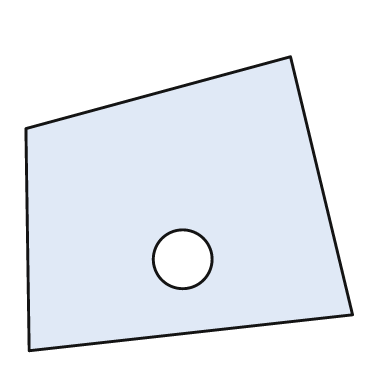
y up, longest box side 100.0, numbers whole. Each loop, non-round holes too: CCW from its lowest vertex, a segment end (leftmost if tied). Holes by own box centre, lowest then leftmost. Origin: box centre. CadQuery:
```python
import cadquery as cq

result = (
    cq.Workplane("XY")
    .moveTo(-49.0, -45.0)
    .lineTo(50.0, -34.0)
    .lineTo(31.0, 45.0)
    .lineTo(-50.0, 23.0)
    .close()
    .moveTo(-2.0, -17.0)
    .circle(9.0)
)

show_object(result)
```